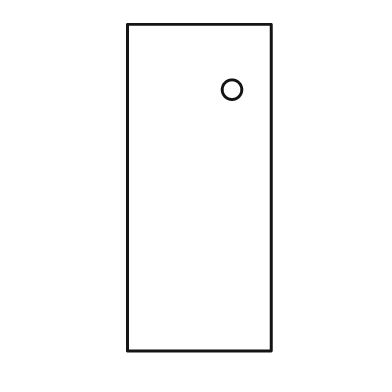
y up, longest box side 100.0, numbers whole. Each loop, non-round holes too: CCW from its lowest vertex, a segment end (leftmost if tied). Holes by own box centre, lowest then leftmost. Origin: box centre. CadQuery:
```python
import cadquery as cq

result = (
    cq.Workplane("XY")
    .moveTo(-22.0, -50.0)
    .lineTo(22.0, -50.0)
    .lineTo(22.0, 50.0)
    .lineTo(-22.0, 50.0)
    .close()
    .moveTo(10.0, 30.0)
    .circle(3.0)
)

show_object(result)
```